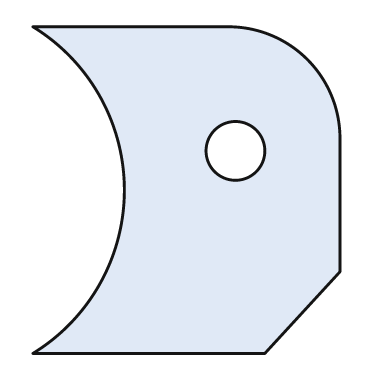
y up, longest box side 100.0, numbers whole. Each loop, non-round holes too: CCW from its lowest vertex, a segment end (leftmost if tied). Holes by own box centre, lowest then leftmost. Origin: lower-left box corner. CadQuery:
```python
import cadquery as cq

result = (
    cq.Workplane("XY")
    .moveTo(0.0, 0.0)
    .lineTo(71.0, 0.0)
    .lineTo(94.0, 25.0)
    .lineTo(94.0, 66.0)
    .threePointArc((84.0, 90.0), (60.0, 100.0))
    .lineTo(0.0, 100.0)
    .threePointArc((28.0, 50.0), (0.0, 0.0))
    .close()
    .moveTo(62.0, 62.0)
    .circle(9.0)
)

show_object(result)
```